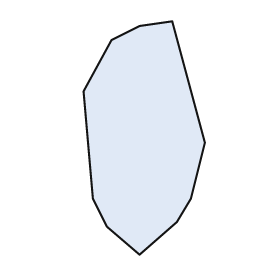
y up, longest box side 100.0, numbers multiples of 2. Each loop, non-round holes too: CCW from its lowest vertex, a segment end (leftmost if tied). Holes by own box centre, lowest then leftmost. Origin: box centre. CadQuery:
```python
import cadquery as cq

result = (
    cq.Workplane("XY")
    .moveTo(-2.0, -50.0)
    .lineTo(14.0, -36.0)
    .lineTo(20.0, -26.0)
    .lineTo(26.0, -2.0)
    .lineTo(12.0, 50.0)
    .lineTo(-2.0, 48.0)
    .lineTo(-14.0, 42.0)
    .lineTo(-26.0, 20.0)
    .lineTo(-22.0, -26.0)
    .lineTo(-16.0, -38.0)
    .close()
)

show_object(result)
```